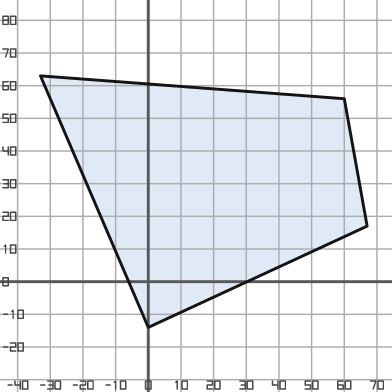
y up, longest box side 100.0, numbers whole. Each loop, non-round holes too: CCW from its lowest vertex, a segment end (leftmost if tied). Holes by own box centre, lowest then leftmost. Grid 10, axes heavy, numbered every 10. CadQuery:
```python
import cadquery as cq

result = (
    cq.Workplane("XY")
    .moveTo(0.0, -14.0)
    .lineTo(67.0, 17.0)
    .lineTo(60.0, 56.0)
    .lineTo(-33.0, 63.0)
    .close()
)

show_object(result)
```